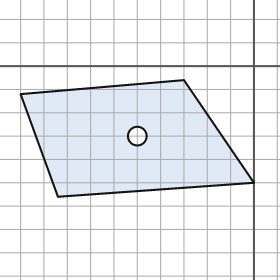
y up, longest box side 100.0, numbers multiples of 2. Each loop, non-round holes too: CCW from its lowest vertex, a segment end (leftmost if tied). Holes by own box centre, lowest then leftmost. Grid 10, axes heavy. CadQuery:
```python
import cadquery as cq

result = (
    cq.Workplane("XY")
    .moveTo(-84.0, -56.0)
    .lineTo(0.0, -50.0)
    .lineTo(-30.0, -6.0)
    .lineTo(-100.0, -12.0)
    .close()
    .moveTo(-50.0, -30.0)
    .circle(4.0)
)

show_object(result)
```